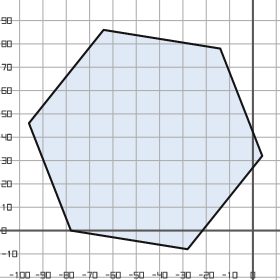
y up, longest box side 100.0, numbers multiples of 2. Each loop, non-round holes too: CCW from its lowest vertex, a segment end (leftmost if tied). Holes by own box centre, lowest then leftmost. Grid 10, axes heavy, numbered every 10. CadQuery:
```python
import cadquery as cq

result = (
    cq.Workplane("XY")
    .moveTo(-28.0, -8.0)
    .lineTo(4.0, 32.0)
    .lineTo(-14.0, 78.0)
    .lineTo(-64.0, 86.0)
    .lineTo(-96.0, 46.0)
    .lineTo(-78.0, 0.0)
    .close()
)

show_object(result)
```